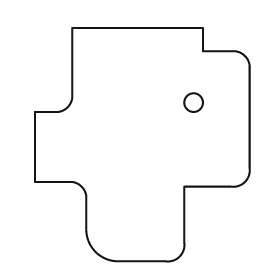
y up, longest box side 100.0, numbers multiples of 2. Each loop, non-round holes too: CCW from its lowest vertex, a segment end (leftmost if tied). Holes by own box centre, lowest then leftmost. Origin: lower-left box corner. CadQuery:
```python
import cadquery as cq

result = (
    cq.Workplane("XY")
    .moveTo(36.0, 0.0)
    .lineTo(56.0, 0.0)
    .threePointArc((62.0, 2.0), (64.0, 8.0))
    .lineTo(64.0, 32.0)
    .lineTo(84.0, 32.0)
    .threePointArc((90.0, 34.0), (92.0, 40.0))
    .lineTo(92.0, 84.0)
    .threePointArc((90.0, 88.0), (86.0, 90.0))
    .lineTo(72.0, 90.0)
    .lineTo(72.0, 100.0)
    .lineTo(16.0, 100.0)
    .lineTo(16.0, 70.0)
    .threePointArc((14.0, 66.0), (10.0, 64.0))
    .lineTo(0.0, 64.0)
    .lineTo(0.0, 34.0)
    .lineTo(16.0, 34.0)
    .threePointArc((20.0, 32.0), (22.0, 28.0))
    .lineTo(22.0, 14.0)
    .threePointArc((26.0, 4.0), (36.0, 0.0))
    .close()
    .moveTo(68.0, 68.0)
    .circle(4.0)
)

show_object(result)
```